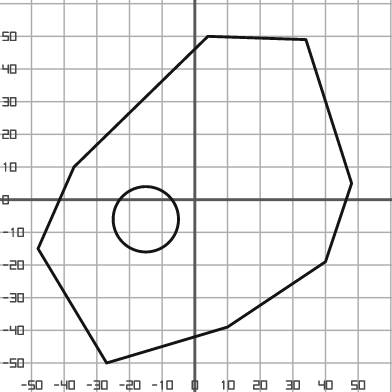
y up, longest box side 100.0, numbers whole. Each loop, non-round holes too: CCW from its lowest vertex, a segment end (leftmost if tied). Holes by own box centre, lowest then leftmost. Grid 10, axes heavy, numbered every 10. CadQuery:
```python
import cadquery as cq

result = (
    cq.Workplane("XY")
    .moveTo(-27.0, -50.0)
    .lineTo(10.0, -39.0)
    .lineTo(40.0, -19.0)
    .lineTo(48.0, 5.0)
    .lineTo(34.0, 49.0)
    .lineTo(4.0, 50.0)
    .lineTo(-37.0, 10.0)
    .lineTo(-48.0, -15.0)
    .close()
    .moveTo(-15.0, -6.0)
    .circle(10.0)
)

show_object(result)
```